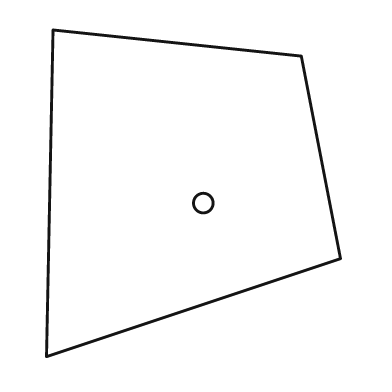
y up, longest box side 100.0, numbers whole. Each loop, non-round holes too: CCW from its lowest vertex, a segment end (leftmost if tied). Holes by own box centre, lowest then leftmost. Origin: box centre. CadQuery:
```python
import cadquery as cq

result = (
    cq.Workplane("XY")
    .moveTo(-45.0, -50.0)
    .lineTo(45.0, -20.0)
    .lineTo(33.0, 42.0)
    .lineTo(-43.0, 50.0)
    .close()
    .moveTo(3.0, -3.0)
    .circle(3.0)
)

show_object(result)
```